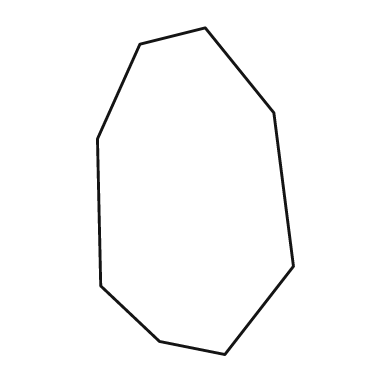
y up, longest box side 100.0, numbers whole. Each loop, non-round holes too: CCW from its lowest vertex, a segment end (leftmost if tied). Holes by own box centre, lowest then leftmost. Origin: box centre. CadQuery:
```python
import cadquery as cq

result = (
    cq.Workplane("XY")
    .moveTo(9.0, -50.0)
    .lineTo(30.0, -23.0)
    .lineTo(24.0, 24.0)
    .lineTo(3.0, 50.0)
    .lineTo(-17.0, 45.0)
    .lineTo(-30.0, 16.0)
    .lineTo(-29.0, -29.0)
    .lineTo(-11.0, -46.0)
    .close()
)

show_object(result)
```